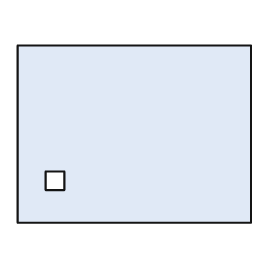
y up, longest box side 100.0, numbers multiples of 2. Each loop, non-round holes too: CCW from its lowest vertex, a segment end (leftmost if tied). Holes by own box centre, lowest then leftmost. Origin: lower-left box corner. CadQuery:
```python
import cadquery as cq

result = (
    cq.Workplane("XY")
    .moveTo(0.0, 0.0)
    .lineTo(100.0, 0.0)
    .lineTo(100.0, 76.0)
    .lineTo(0.0, 76.0)
    .close()
    .moveTo(12.0, 14.0)
    .lineTo(20.0, 14.0)
    .lineTo(20.0, 22.0)
    .lineTo(12.0, 22.0)
    .close()
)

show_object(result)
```